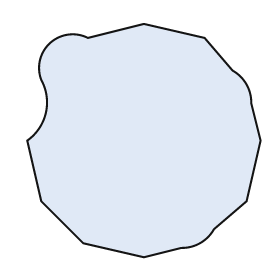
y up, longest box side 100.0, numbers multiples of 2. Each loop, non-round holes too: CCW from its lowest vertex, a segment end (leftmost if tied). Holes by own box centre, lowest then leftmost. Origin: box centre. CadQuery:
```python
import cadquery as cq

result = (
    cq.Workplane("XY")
    .moveTo(0.0, -50.0)
    .lineTo(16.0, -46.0)
    .threePointArc((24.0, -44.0), (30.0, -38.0))
    .lineTo(44.0, -26.0)
    .lineTo(50.0, 0.0)
    .lineTo(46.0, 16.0)
    .threePointArc((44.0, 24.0), (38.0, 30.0))
    .lineTo(26.0, 44.0)
    .lineTo(0.0, 50.0)
    .lineTo(-24.0, 44.0)
    .threePointArc((-40.0, 42.0), (-44.0, 26.0))
    .threePointArc((-42.0, 12.0), (-50.0, 0.0))
    .lineTo(-44.0, -26.0)
    .lineTo(-26.0, -44.0)
    .close()
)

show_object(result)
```